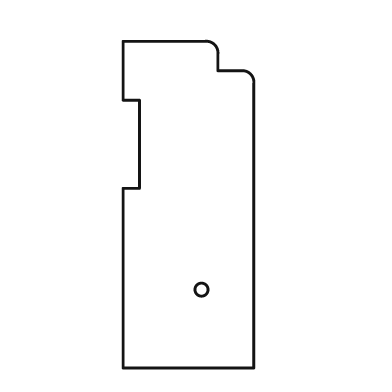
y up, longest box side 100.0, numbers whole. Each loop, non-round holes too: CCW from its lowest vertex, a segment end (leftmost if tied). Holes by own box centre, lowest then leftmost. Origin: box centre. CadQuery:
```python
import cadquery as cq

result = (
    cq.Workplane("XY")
    .moveTo(-20.0, -50.0)
    .lineTo(20.0, -50.0)
    .lineTo(20.0, 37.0)
    .threePointArc((19.0, 40.0), (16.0, 41.0))
    .lineTo(9.0, 41.0)
    .lineTo(9.0, 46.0)
    .threePointArc((8.0, 49.0), (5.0, 50.0))
    .lineTo(-20.0, 50.0)
    .lineTo(-20.0, 32.0)
    .lineTo(-15.0, 32.0)
    .lineTo(-15.0, 5.0)
    .lineTo(-20.0, 5.0)
    .close()
    .moveTo(4.0, -26.0)
    .circle(2.0)
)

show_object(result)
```